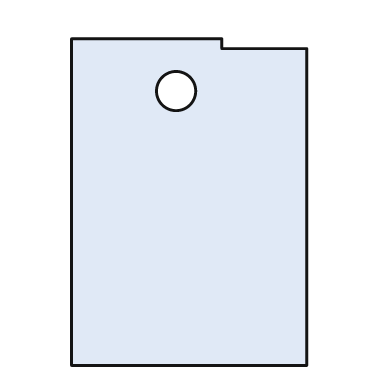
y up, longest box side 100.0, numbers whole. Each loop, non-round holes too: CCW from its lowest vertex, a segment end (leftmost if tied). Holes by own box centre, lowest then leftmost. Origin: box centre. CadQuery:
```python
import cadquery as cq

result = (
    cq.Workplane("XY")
    .moveTo(-36.0, -50.0)
    .lineTo(36.0, -50.0)
    .lineTo(36.0, 47.0)
    .lineTo(10.0, 47.0)
    .lineTo(10.0, 50.0)
    .lineTo(-36.0, 50.0)
    .close()
    .moveTo(-4.0, 34.0)
    .circle(6.0)
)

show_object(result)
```